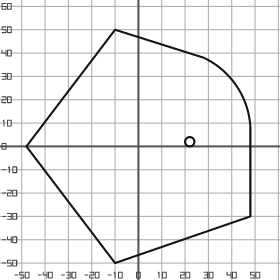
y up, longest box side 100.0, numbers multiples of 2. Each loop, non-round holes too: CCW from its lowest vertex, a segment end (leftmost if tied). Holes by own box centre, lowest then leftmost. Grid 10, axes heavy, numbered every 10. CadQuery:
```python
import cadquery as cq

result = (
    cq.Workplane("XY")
    .moveTo(-10.0, -50.0)
    .lineTo(48.0, -30.0)
    .lineTo(48.0, 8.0)
    .threePointArc((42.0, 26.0), (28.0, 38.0))
    .lineTo(-10.0, 50.0)
    .lineTo(-48.0, 0.0)
    .close()
    .moveTo(22.0, 2.0)
    .circle(2.0)
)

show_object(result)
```